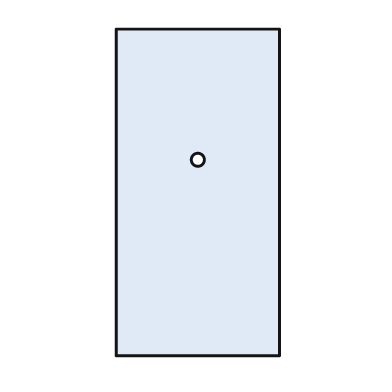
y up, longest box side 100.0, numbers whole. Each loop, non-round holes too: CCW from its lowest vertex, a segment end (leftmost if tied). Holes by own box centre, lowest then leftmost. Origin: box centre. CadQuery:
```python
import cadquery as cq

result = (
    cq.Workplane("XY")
    .moveTo(-25.0, -50.0)
    .lineTo(25.0, -50.0)
    .lineTo(25.0, 50.0)
    .lineTo(-25.0, 50.0)
    .close()
    .moveTo(0.0, 10.0)
    .circle(2.0)
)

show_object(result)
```